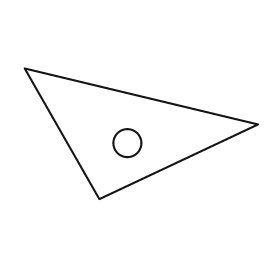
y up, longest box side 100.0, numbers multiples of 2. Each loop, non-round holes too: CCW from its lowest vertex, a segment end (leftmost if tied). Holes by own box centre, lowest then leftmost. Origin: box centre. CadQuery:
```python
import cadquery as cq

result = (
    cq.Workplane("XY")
    .moveTo(-18.0, -28.0)
    .lineTo(50.0, 4.0)
    .lineTo(-50.0, 28.0)
    .close()
    .moveTo(-6.0, -4.0)
    .circle(6.0)
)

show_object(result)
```